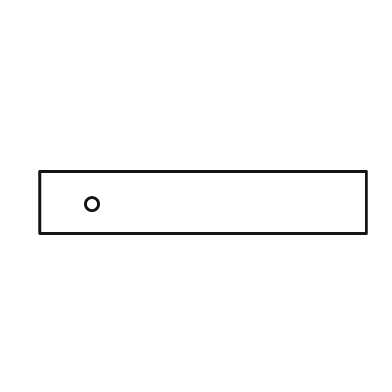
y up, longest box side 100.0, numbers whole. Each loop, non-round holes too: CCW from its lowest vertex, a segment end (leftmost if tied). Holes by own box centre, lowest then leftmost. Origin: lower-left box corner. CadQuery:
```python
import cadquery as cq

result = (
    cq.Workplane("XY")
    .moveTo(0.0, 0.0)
    .lineTo(100.0, 0.0)
    .lineTo(100.0, 19.0)
    .lineTo(0.0, 19.0)
    .close()
    .moveTo(16.0, 9.0)
    .circle(2.0)
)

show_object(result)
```